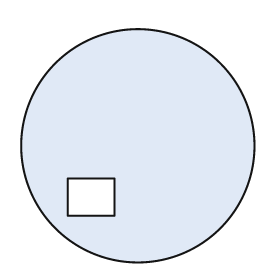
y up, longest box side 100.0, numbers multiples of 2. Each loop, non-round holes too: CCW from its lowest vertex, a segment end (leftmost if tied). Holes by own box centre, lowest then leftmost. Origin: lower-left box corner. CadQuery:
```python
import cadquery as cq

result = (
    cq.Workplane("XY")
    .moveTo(50.0, 50.0)
    .circle(50.0)
    .moveTo(20.0, 20.0)
    .lineTo(40.0, 20.0)
    .lineTo(40.0, 36.0)
    .lineTo(20.0, 36.0)
    .close()
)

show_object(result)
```